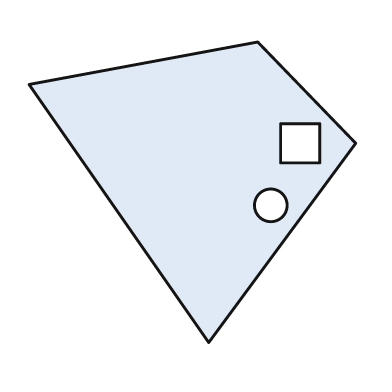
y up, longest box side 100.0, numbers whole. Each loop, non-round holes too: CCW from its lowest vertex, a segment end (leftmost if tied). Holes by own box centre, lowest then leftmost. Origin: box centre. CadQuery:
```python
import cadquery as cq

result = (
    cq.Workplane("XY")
    .moveTo(5.0, -46.0)
    .lineTo(50.0, 15.0)
    .lineTo(20.0, 46.0)
    .lineTo(-50.0, 33.0)
    .close()
    .moveTo(24.0, -4.0)
    .circle(5.0)
    .moveTo(27.0, 9.0)
    .lineTo(39.0, 9.0)
    .lineTo(39.0, 21.0)
    .lineTo(27.0, 21.0)
    .close()
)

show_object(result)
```